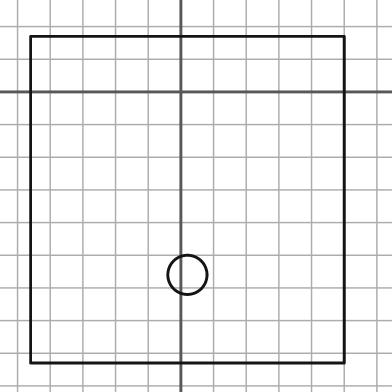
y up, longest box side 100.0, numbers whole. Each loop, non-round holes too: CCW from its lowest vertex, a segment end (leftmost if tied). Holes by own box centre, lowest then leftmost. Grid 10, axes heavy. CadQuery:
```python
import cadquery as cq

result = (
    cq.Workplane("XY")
    .moveTo(-46.0, -83.0)
    .lineTo(50.0, -83.0)
    .lineTo(50.0, 17.0)
    .lineTo(-46.0, 17.0)
    .close()
    .moveTo(2.0, -56.0)
    .circle(6.0)
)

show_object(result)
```